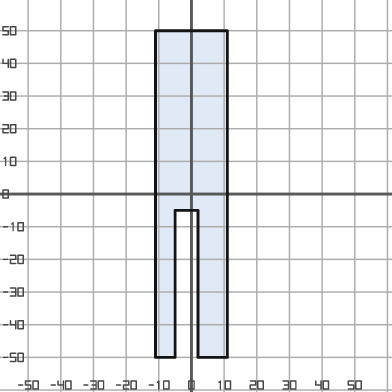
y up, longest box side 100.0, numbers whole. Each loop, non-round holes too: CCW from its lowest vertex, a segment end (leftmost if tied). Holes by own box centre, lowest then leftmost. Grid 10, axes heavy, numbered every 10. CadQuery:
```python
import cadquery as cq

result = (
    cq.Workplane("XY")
    .moveTo(-11.0, -50.0)
    .lineTo(-5.0, -50.0)
    .lineTo(-5.0, -5.0)
    .lineTo(2.0, -5.0)
    .lineTo(2.0, -50.0)
    .lineTo(11.0, -50.0)
    .lineTo(11.0, 50.0)
    .lineTo(-11.0, 50.0)
    .close()
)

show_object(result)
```